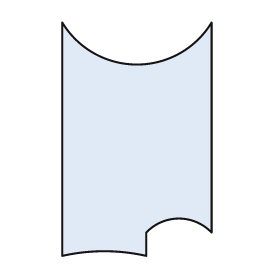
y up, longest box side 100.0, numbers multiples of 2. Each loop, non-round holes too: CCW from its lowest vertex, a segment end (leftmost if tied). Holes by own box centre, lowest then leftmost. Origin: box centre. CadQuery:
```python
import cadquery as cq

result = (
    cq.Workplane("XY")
    .moveTo(-32.0, -50.0)
    .threePointArc((-14.0, -48.0), (4.0, -50.0))
    .lineTo(4.0, -40.0)
    .threePointArc((18.0, -34.0), (32.0, -40.0))
    .lineTo(32.0, 50.0)
    .threePointArc((0.0, 32.0), (-32.0, 50.0))
    .close()
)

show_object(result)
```